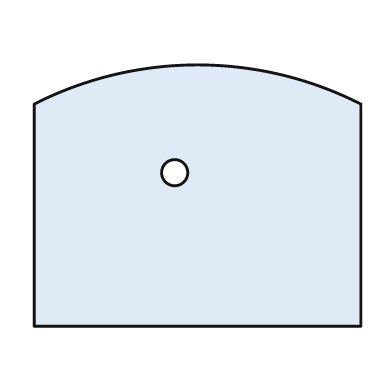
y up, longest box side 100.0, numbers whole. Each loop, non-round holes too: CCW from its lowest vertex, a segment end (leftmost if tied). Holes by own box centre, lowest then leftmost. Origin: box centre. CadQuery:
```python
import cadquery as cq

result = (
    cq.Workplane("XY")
    .moveTo(-50.0, -40.0)
    .lineTo(50.0, -40.0)
    .lineTo(50.0, 28.0)
    .threePointArc((0.0, 40.0), (-50.0, 28.0))
    .close()
    .moveTo(-7.0, 7.0)
    .circle(4.0)
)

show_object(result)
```